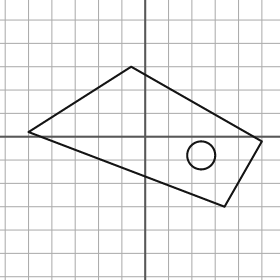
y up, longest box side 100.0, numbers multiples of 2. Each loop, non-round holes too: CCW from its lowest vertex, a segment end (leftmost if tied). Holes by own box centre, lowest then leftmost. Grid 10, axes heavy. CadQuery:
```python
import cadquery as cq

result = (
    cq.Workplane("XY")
    .moveTo(34.0, -30.0)
    .lineTo(50.0, -2.0)
    .lineTo(-6.0, 30.0)
    .lineTo(-50.0, 2.0)
    .close()
    .moveTo(24.0, -8.0)
    .circle(6.0)
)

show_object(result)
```